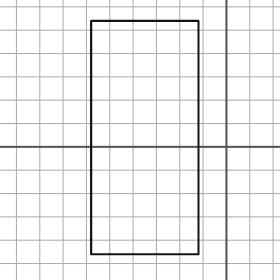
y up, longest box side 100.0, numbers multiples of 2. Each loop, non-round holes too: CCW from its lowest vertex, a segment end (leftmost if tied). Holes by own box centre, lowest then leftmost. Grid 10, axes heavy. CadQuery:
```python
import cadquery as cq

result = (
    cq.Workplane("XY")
    .moveTo(-58.0, -46.0)
    .lineTo(-12.0, -46.0)
    .lineTo(-12.0, 54.0)
    .lineTo(-58.0, 54.0)
    .close()
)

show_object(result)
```